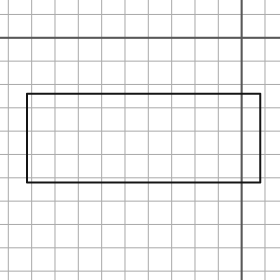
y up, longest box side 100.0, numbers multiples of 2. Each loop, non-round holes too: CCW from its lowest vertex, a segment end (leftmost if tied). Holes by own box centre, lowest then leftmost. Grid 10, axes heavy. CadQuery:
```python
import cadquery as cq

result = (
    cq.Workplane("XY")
    .moveTo(-92.0, -62.0)
    .lineTo(8.0, -62.0)
    .lineTo(8.0, -24.0)
    .lineTo(-92.0, -24.0)
    .close()
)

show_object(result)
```